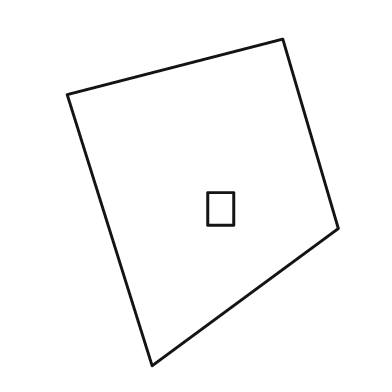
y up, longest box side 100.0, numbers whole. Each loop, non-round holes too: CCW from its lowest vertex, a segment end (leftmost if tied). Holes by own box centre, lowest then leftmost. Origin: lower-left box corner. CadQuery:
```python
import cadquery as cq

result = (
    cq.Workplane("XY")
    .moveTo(26.0, 0.0)
    .lineTo(83.0, 42.0)
    .lineTo(66.0, 100.0)
    .lineTo(0.0, 83.0)
    .close()
    .moveTo(43.0, 43.0)
    .lineTo(51.0, 43.0)
    .lineTo(51.0, 53.0)
    .lineTo(43.0, 53.0)
    .close()
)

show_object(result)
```